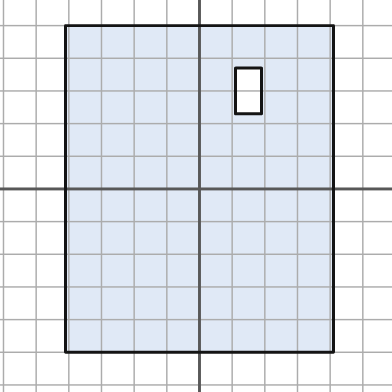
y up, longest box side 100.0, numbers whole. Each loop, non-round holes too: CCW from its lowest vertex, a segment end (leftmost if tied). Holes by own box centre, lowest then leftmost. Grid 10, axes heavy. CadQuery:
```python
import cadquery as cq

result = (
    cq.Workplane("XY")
    .moveTo(-41.0, -50.0)
    .lineTo(41.0, -50.0)
    .lineTo(41.0, 50.0)
    .lineTo(-41.0, 50.0)
    .close()
    .moveTo(11.0, 23.0)
    .lineTo(19.0, 23.0)
    .lineTo(19.0, 37.0)
    .lineTo(11.0, 37.0)
    .close()
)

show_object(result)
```